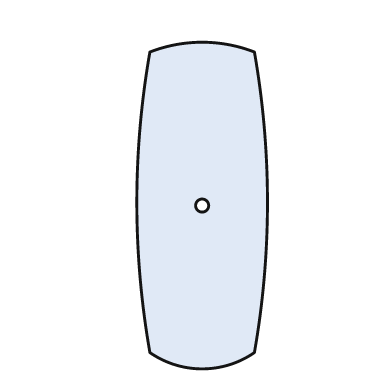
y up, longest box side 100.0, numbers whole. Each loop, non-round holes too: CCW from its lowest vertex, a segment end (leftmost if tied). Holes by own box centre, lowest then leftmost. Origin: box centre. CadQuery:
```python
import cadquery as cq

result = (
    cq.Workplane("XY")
    .moveTo(-16.0, -45.0)
    .threePointArc((0.0, -50.0), (16.0, -45.0))
    .threePointArc((20.0, 1.0), (16.0, 47.0))
    .threePointArc((0.0, 50.0), (-16.0, 47.0))
    .threePointArc((-20.0, 1.0), (-16.0, -45.0))
    .close()
    .moveTo(0.0, 0.0)
    .circle(2.0)
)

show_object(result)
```